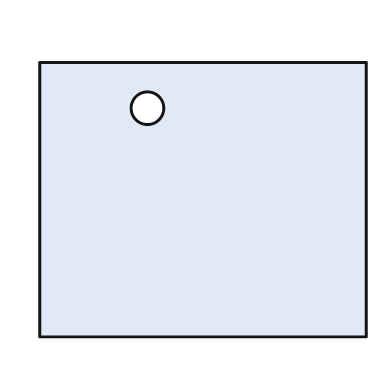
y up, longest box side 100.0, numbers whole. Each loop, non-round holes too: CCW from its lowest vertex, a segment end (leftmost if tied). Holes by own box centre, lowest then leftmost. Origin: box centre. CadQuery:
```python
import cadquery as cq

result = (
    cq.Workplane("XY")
    .moveTo(-50.0, -42.0)
    .lineTo(50.0, -42.0)
    .lineTo(50.0, 42.0)
    .lineTo(-50.0, 42.0)
    .close()
    .moveTo(-17.0, 28.0)
    .circle(5.0)
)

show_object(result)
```